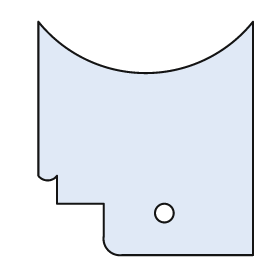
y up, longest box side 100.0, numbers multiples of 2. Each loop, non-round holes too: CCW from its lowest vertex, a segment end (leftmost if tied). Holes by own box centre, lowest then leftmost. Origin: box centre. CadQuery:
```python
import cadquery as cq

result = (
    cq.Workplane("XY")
    .moveTo(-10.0, -50.0)
    .lineTo(46.0, -50.0)
    .lineTo(46.0, 50.0)
    .threePointArc((0.0, 28.0), (-46.0, 50.0))
    .lineTo(-46.0, -16.0)
    .threePointArc((-42.0, -18.0), (-38.0, -16.0))
    .lineTo(-38.0, -28.0)
    .lineTo(-18.0, -28.0)
    .lineTo(-18.0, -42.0)
    .threePointArc((-16.0, -48.0), (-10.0, -50.0))
    .close()
    .moveTo(8.0, -32.0)
    .circle(4.0)
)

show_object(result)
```